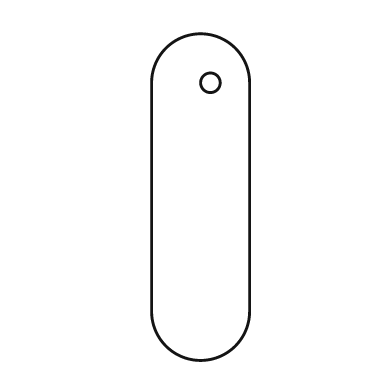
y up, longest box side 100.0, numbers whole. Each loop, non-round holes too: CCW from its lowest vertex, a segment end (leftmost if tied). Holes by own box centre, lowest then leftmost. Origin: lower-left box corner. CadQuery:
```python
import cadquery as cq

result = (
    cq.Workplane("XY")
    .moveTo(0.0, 15.0)
    .threePointArc((15.0, 0.0), (30.0, 15.0))
    .lineTo(30.0, 85.0)
    .threePointArc((15.0, 100.0), (0.0, 85.0))
    .close()
    .moveTo(18.0, 85.0)
    .circle(3.0)
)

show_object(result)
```